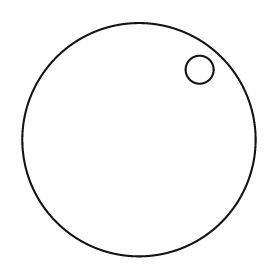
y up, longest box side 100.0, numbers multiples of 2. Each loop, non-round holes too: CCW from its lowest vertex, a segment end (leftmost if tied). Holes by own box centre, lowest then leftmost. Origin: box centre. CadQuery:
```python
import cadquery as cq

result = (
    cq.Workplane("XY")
    .moveTo(0.0, 0.0)
    .circle(50.0)
    .moveTo(26.0, 30.0)
    .circle(6.0)
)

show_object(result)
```